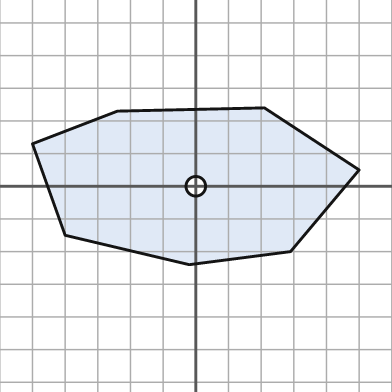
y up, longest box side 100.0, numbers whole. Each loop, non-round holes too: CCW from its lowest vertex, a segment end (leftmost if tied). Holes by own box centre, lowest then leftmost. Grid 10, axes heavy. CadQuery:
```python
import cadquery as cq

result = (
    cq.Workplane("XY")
    .moveTo(-2.0, -24.0)
    .lineTo(29.0, -20.0)
    .lineTo(50.0, 5.0)
    .lineTo(21.0, 24.0)
    .lineTo(-24.0, 23.0)
    .lineTo(-50.0, 13.0)
    .lineTo(-40.0, -15.0)
    .close()
    .moveTo(0.0, 0.0)
    .circle(3.0)
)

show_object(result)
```